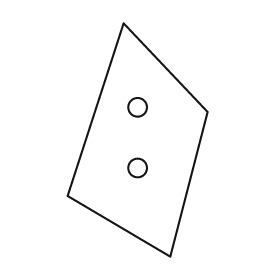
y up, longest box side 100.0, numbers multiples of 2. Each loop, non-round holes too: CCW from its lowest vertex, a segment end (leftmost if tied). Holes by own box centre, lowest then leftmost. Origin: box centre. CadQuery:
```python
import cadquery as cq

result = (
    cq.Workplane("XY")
    .moveTo(14.0, -50.0)
    .lineTo(30.0, 12.0)
    .lineTo(-6.0, 50.0)
    .lineTo(-30.0, -24.0)
    .close()
    .moveTo(0.0, -12.0)
    .circle(4.0)
    .moveTo(0.0, 14.0)
    .circle(4.0)
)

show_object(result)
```